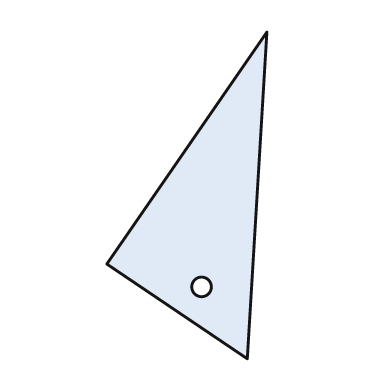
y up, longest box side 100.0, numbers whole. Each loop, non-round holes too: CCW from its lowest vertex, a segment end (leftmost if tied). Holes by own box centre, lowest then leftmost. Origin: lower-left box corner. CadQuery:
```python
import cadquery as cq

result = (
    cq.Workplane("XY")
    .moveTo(43.0, 0.0)
    .lineTo(49.0, 100.0)
    .lineTo(0.0, 29.0)
    .close()
    .moveTo(29.0, 22.0)
    .circle(3.0)
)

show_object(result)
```